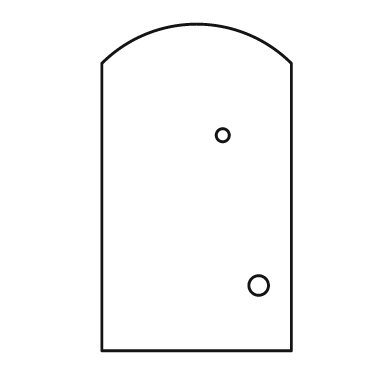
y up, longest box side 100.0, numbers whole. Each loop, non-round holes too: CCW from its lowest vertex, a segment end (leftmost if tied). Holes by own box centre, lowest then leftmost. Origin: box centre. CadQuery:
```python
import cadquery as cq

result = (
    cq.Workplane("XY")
    .moveTo(-29.0, -50.0)
    .lineTo(29.0, -50.0)
    .lineTo(29.0, 38.0)
    .threePointArc((0.0, 50.0), (-29.0, 38.0))
    .close()
    .moveTo(19.0, -30.0)
    .circle(3.0)
    .moveTo(8.0, 16.0)
    .circle(2.0)
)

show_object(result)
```